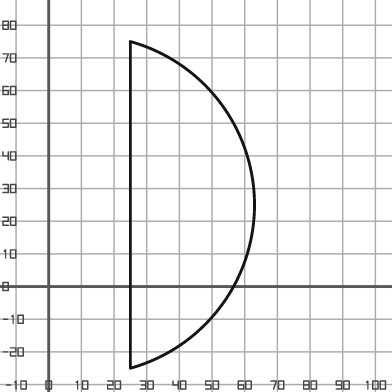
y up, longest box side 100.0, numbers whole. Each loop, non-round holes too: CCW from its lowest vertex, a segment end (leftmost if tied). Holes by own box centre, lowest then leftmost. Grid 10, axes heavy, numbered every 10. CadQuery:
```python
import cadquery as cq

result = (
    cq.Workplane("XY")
    .moveTo(25.0, -25.0)
    .threePointArc((63.0, 25.0), (25.0, 75.0))
    .close()
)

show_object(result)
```